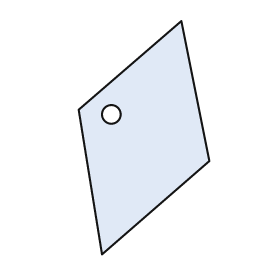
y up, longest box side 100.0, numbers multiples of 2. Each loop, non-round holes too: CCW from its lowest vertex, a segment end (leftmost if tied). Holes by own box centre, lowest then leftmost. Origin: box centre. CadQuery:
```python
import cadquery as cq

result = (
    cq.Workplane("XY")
    .moveTo(-18.0, -50.0)
    .lineTo(28.0, -10.0)
    .lineTo(16.0, 50.0)
    .lineTo(-28.0, 12.0)
    .close()
    .moveTo(-14.0, 10.0)
    .circle(4.0)
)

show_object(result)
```